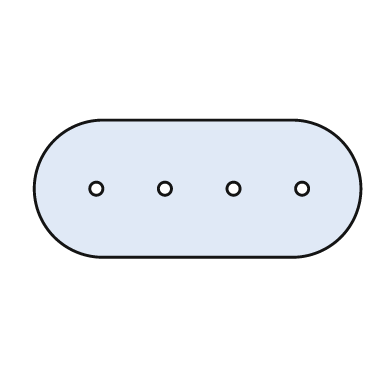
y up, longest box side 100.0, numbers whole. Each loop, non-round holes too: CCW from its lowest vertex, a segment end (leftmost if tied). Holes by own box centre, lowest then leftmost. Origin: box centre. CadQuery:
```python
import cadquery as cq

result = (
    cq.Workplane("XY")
    .moveTo(-29.0, -21.0)
    .lineTo(29.0, -21.0)
    .threePointArc((50.0, 0.0), (29.0, 21.0))
    .lineTo(-29.0, 21.0)
    .threePointArc((-50.0, 0.0), (-29.0, -21.0))
    .close()
    .moveTo(-31.0, 0.0)
    .circle(2.0)
    .moveTo(-10.0, 0.0)
    .circle(2.0)
    .moveTo(11.0, 0.0)
    .circle(2.0)
    .moveTo(32.0, 0.0)
    .circle(2.0)
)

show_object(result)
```